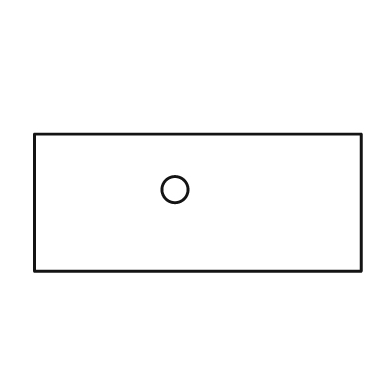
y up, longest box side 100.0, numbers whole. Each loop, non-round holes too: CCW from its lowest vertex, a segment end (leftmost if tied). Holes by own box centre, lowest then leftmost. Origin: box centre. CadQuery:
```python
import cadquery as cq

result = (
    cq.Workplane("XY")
    .moveTo(-50.0, -21.0)
    .lineTo(50.0, -21.0)
    .lineTo(50.0, 21.0)
    .lineTo(-50.0, 21.0)
    .close()
    .moveTo(-7.0, 4.0)
    .circle(4.0)
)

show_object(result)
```